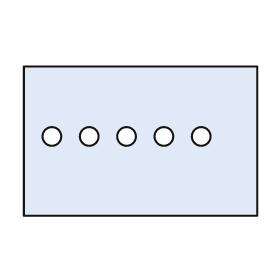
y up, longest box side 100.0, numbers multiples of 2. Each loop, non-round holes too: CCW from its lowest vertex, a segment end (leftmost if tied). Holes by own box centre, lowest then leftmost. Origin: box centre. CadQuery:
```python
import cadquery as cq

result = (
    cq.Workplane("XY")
    .moveTo(-50.0, -32.0)
    .lineTo(50.0, -32.0)
    .lineTo(50.0, 32.0)
    .lineTo(-50.0, 32.0)
    .close()
    .moveTo(-38.0, 2.0)
    .circle(4.0)
    .moveTo(-22.0, 2.0)
    .circle(4.0)
    .moveTo(-6.0, 2.0)
    .circle(4.0)
    .moveTo(10.0, 2.0)
    .circle(4.0)
    .moveTo(26.0, 2.0)
    .circle(4.0)
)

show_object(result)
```